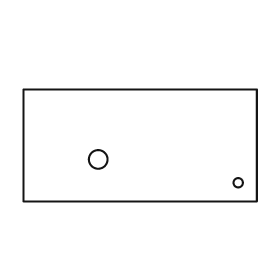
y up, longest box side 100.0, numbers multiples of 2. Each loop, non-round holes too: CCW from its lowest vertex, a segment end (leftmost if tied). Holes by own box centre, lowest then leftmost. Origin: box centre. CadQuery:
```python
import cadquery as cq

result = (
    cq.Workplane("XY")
    .moveTo(-50.0, -24.0)
    .lineTo(50.0, -24.0)
    .lineTo(50.0, 24.0)
    .lineTo(-50.0, 24.0)
    .close()
    .moveTo(42.0, -16.0)
    .circle(2.0)
    .moveTo(-18.0, -6.0)
    .circle(4.0)
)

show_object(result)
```